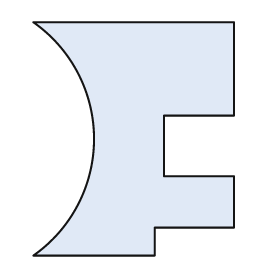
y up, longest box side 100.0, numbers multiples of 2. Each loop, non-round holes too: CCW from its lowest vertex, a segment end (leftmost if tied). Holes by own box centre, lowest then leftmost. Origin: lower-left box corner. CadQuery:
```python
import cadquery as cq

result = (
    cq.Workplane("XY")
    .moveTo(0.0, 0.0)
    .lineTo(52.0, 0.0)
    .lineTo(52.0, 12.0)
    .lineTo(86.0, 12.0)
    .lineTo(86.0, 34.0)
    .lineTo(56.0, 34.0)
    .lineTo(56.0, 60.0)
    .lineTo(86.0, 60.0)
    .lineTo(86.0, 100.0)
    .lineTo(0.0, 100.0)
    .threePointArc((26.0, 50.0), (0.0, 0.0))
    .close()
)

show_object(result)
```